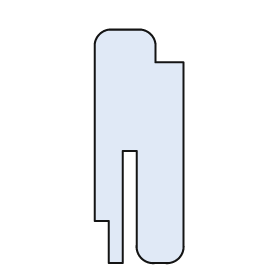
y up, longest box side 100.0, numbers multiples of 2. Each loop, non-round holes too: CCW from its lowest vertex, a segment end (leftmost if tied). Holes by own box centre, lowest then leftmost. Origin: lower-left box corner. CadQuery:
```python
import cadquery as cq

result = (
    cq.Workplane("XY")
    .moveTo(6.0, 0.0)
    .lineTo(12.0, 0.0)
    .lineTo(12.0, 48.0)
    .lineTo(18.0, 48.0)
    .lineTo(18.0, 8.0)
    .threePointArc((20.0, 2.0), (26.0, 0.0))
    .lineTo(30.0, 0.0)
    .threePointArc((36.0, 2.0), (38.0, 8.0))
    .lineTo(38.0, 86.0)
    .lineTo(26.0, 86.0)
    .lineTo(26.0, 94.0)
    .threePointArc((24.0, 98.0), (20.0, 100.0))
    .lineTo(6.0, 100.0)
    .threePointArc((2.0, 98.0), (0.0, 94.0))
    .lineTo(0.0, 18.0)
    .lineTo(6.0, 18.0)
    .close()
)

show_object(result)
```